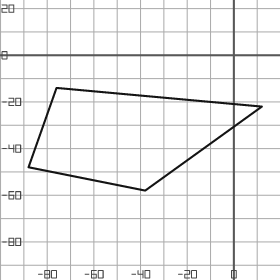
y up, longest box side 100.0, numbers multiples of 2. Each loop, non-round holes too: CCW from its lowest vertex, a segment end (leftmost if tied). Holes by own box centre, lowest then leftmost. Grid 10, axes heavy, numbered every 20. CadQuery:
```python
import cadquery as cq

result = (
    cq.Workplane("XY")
    .moveTo(-38.0, -58.0)
    .lineTo(12.0, -22.0)
    .lineTo(-76.0, -14.0)
    .lineTo(-88.0, -48.0)
    .close()
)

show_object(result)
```